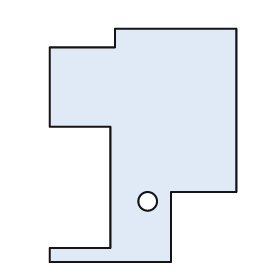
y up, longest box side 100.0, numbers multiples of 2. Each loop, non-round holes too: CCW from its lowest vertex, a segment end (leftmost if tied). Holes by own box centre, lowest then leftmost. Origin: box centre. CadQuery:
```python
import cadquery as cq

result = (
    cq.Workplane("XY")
    .moveTo(-40.0, -50.0)
    .lineTo(12.0, -50.0)
    .lineTo(12.0, -20.0)
    .lineTo(40.0, -20.0)
    .lineTo(40.0, 50.0)
    .lineTo(-12.0, 50.0)
    .lineTo(-12.0, 42.0)
    .lineTo(-40.0, 42.0)
    .lineTo(-40.0, 8.0)
    .lineTo(-14.0, 8.0)
    .lineTo(-14.0, -44.0)
    .lineTo(-40.0, -44.0)
    .close()
    .moveTo(2.0, -24.0)
    .circle(4.0)
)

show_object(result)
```